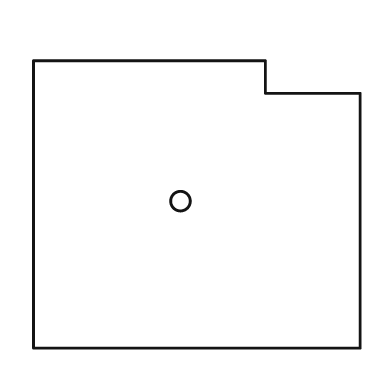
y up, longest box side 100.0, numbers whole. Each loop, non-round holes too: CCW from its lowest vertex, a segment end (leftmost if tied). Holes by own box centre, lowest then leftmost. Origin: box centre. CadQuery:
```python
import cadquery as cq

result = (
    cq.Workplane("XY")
    .moveTo(-50.0, -44.0)
    .lineTo(50.0, -44.0)
    .lineTo(50.0, 34.0)
    .lineTo(21.0, 34.0)
    .lineTo(21.0, 44.0)
    .lineTo(-50.0, 44.0)
    .close()
    .moveTo(-5.0, 1.0)
    .circle(3.0)
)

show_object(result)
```